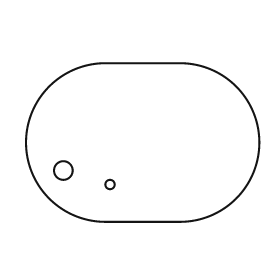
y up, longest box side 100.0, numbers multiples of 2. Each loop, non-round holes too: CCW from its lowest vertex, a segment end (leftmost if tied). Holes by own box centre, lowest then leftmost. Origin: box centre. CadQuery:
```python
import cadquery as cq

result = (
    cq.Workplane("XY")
    .moveTo(-16.0, -34.0)
    .lineTo(16.0, -34.0)
    .threePointArc((50.0, 0.0), (16.0, 34.0))
    .lineTo(-16.0, 34.0)
    .threePointArc((-50.0, 0.0), (-16.0, -34.0))
    .close()
    .moveTo(-14.0, -18.0)
    .circle(2.0)
    .moveTo(-34.0, -12.0)
    .circle(4.0)
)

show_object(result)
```